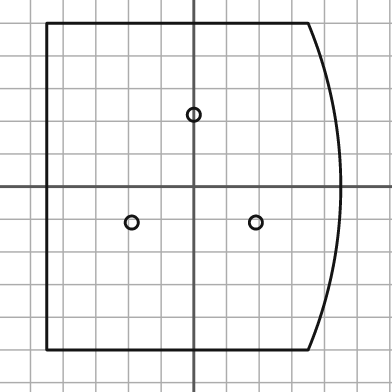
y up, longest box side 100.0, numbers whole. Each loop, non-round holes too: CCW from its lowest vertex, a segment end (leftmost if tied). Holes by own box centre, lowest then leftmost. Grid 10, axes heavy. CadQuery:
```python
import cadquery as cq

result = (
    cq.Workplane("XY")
    .moveTo(-45.0, -50.0)
    .lineTo(35.0, -50.0)
    .threePointArc((45.0, 0.0), (35.0, 50.0))
    .lineTo(-45.0, 50.0)
    .close()
    .moveTo(-19.0, -11.0)
    .circle(2.0)
    .moveTo(19.0, -11.0)
    .circle(2.0)
    .moveTo(0.0, 22.0)
    .circle(2.0)
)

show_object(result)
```